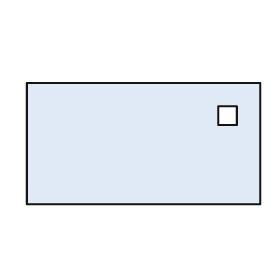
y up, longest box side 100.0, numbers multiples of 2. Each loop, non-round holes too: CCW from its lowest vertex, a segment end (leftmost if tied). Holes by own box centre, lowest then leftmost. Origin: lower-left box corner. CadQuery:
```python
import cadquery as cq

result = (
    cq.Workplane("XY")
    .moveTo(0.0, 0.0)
    .lineTo(100.0, 0.0)
    .lineTo(100.0, 52.0)
    .lineTo(0.0, 52.0)
    .close()
    .moveTo(82.0, 34.0)
    .lineTo(90.0, 34.0)
    .lineTo(90.0, 42.0)
    .lineTo(82.0, 42.0)
    .close()
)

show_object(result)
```